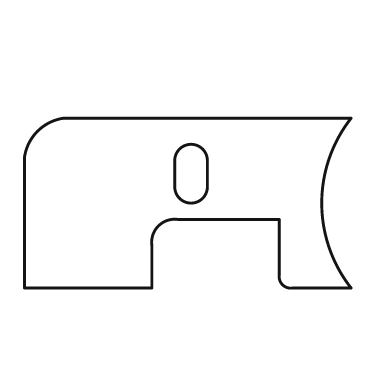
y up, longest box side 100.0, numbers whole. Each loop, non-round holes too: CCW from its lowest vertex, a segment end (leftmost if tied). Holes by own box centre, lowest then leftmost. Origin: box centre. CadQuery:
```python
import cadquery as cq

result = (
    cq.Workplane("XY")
    .moveTo(-50.0, -26.0)
    .lineTo(-11.0, -26.0)
    .lineTo(-11.0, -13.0)
    .threePointArc((-9.0, -7.0), (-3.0, -5.0))
    .lineTo(28.0, -5.0)
    .lineTo(28.0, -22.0)
    .threePointArc((29.0, -25.0), (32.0, -26.0))
    .lineTo(50.0, -26.0)
    .threePointArc((41.0, 0.0), (50.0, 26.0))
    .lineTo(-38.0, 26.0)
    .threePointArc((-46.0, 22.0), (-50.0, 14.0))
    .close()
    .moveTo(-4.0, 5.0)
    .threePointArc((1.0, 0.0), (6.0, 5.0))
    .lineTo(6.0, 13.0)
    .threePointArc((1.0, 18.0), (-4.0, 13.0))
    .close()
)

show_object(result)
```